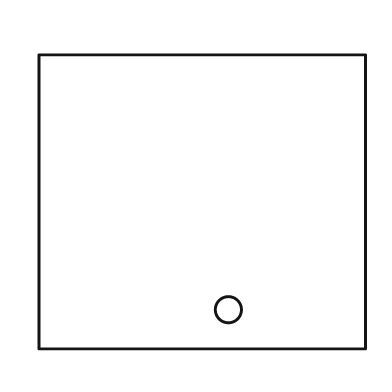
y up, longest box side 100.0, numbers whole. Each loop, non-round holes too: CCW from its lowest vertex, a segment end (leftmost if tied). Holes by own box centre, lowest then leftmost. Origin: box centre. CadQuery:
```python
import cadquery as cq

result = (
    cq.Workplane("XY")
    .moveTo(-50.0, -45.0)
    .lineTo(50.0, -45.0)
    .lineTo(50.0, 45.0)
    .lineTo(-50.0, 45.0)
    .close()
    .moveTo(8.0, -33.0)
    .circle(4.0)
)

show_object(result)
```